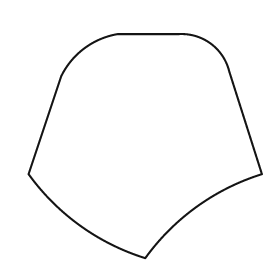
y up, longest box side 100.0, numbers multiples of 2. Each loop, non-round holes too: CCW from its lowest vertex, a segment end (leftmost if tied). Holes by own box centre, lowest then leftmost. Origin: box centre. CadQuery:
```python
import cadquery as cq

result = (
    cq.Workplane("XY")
    .moveTo(0.0, -48.0)
    .threePointArc((22.0, -26.0), (50.0, -12.0))
    .lineTo(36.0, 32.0)
    .threePointArc((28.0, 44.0), (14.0, 48.0))
    .lineTo(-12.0, 48.0)
    .threePointArc((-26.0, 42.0), (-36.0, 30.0))
    .lineTo(-50.0, -12.0)
    .threePointArc((-28.0, -34.0), (0.0, -48.0))
    .close()
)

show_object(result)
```